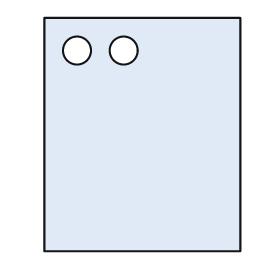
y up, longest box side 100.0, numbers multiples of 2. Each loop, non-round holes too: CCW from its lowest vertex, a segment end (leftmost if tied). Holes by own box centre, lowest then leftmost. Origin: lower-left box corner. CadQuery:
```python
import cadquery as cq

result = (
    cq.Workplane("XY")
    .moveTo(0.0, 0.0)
    .lineTo(84.0, 0.0)
    .lineTo(84.0, 100.0)
    .lineTo(0.0, 100.0)
    .close()
    .moveTo(14.0, 86.0)
    .circle(6.0)
    .moveTo(34.0, 86.0)
    .circle(6.0)
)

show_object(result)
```